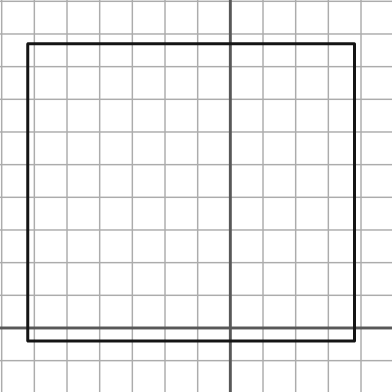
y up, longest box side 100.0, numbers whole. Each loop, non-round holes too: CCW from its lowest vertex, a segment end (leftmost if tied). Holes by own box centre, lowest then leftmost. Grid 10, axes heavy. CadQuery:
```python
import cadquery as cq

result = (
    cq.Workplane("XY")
    .moveTo(-62.0, -4.0)
    .lineTo(38.0, -4.0)
    .lineTo(38.0, 87.0)
    .lineTo(-62.0, 87.0)
    .close()
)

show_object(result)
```